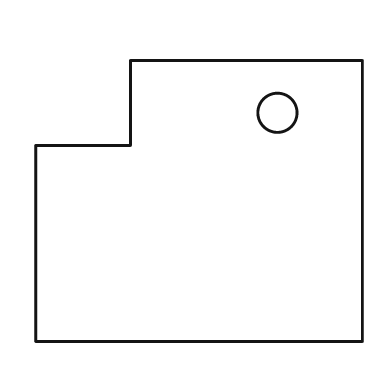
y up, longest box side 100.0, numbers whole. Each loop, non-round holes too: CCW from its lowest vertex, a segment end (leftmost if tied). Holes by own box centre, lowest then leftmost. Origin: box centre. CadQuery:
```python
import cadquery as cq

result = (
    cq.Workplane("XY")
    .moveTo(-50.0, -43.0)
    .lineTo(50.0, -43.0)
    .lineTo(50.0, 43.0)
    .lineTo(-21.0, 43.0)
    .lineTo(-21.0, 17.0)
    .lineTo(-50.0, 17.0)
    .close()
    .moveTo(24.0, 27.0)
    .circle(6.0)
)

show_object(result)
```